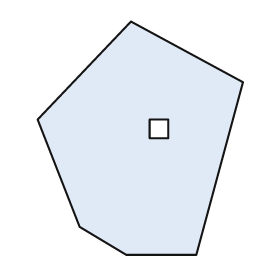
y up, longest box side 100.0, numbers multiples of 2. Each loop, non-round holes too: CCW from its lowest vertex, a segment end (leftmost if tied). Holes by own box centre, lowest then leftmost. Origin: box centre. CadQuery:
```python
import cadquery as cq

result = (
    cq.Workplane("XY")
    .moveTo(-6.0, -50.0)
    .lineTo(24.0, -50.0)
    .lineTo(44.0, 24.0)
    .lineTo(-4.0, 50.0)
    .lineTo(-44.0, 8.0)
    .lineTo(-26.0, -38.0)
    .close()
    .moveTo(4.0, 0.0)
    .lineTo(12.0, 0.0)
    .lineTo(12.0, 8.0)
    .lineTo(4.0, 8.0)
    .close()
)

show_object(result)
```